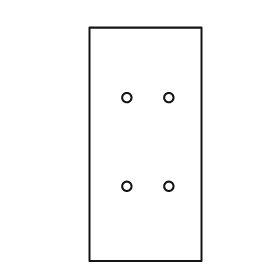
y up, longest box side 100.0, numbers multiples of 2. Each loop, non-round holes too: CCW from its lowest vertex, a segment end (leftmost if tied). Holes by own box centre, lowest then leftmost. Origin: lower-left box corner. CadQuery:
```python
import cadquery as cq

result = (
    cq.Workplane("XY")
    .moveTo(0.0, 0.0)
    .lineTo(48.0, 0.0)
    .lineTo(48.0, 100.0)
    .lineTo(0.0, 100.0)
    .close()
    .moveTo(16.0, 32.0)
    .circle(2.0)
    .moveTo(34.0, 32.0)
    .circle(2.0)
    .moveTo(16.0, 70.0)
    .circle(2.0)
    .moveTo(34.0, 70.0)
    .circle(2.0)
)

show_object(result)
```